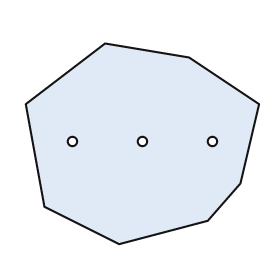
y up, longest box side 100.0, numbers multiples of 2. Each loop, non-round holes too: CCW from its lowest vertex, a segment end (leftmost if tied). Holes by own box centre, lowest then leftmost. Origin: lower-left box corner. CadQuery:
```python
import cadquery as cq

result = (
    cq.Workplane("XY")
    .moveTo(40.0, 0.0)
    .lineTo(78.0, 10.0)
    .lineTo(92.0, 26.0)
    .lineTo(100.0, 60.0)
    .lineTo(70.0, 80.0)
    .lineTo(34.0, 86.0)
    .lineTo(0.0, 60.0)
    .lineTo(8.0, 16.0)
    .close()
    .moveTo(20.0, 44.0)
    .circle(2.0)
    .moveTo(50.0, 44.0)
    .circle(2.0)
    .moveTo(80.0, 44.0)
    .circle(2.0)
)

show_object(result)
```